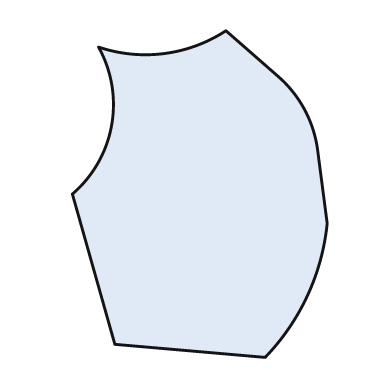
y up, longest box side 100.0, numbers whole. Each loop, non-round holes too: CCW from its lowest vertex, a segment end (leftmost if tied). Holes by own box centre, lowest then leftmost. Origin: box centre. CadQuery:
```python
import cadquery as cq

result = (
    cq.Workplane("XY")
    .moveTo(20.0, -50.0)
    .threePointArc((33.0, -31.0), (39.0, -9.0))
    .lineTo(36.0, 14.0)
    .threePointArc((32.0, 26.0), (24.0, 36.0))
    .lineTo(8.0, 50.0)
    .threePointArc((-11.0, 43.0), (-31.0, 45.0))
    .threePointArc((-27.0, 21.0), (-39.0, 0.0))
    .lineTo(-26.0, -46.0)
    .close()
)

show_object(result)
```